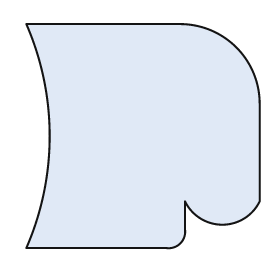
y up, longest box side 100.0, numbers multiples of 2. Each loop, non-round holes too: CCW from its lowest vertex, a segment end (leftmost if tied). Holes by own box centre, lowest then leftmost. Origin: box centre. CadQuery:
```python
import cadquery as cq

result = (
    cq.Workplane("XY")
    .moveTo(-50.0, -48.0)
    .lineTo(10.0, -48.0)
    .threePointArc((16.0, -46.0), (18.0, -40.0))
    .lineTo(18.0, -28.0)
    .threePointArc((34.0, -38.0), (50.0, -28.0))
    .lineTo(50.0, 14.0)
    .threePointArc((40.0, 38.0), (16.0, 48.0))
    .lineTo(-50.0, 48.0)
    .threePointArc((-40.0, 0.0), (-50.0, -48.0))
    .close()
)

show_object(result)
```